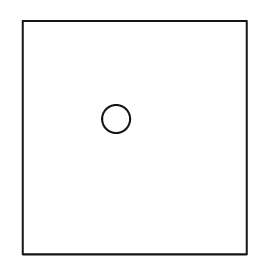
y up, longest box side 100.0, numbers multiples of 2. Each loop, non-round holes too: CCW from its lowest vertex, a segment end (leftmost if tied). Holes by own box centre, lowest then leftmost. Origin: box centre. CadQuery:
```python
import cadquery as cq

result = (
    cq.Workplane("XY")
    .moveTo(-48.0, -50.0)
    .lineTo(48.0, -50.0)
    .lineTo(48.0, 50.0)
    .lineTo(-48.0, 50.0)
    .close()
    .moveTo(-8.0, 8.0)
    .circle(6.0)
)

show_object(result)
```